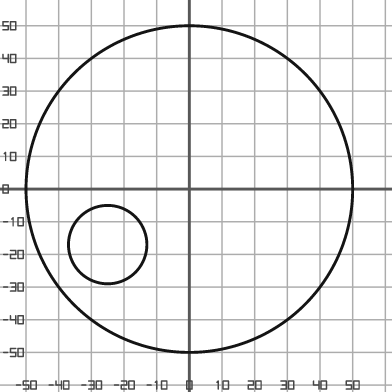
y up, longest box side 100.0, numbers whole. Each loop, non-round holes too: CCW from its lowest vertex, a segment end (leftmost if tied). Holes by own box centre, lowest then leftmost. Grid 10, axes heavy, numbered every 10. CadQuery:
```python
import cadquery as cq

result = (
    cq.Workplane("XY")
    .moveTo(0.0, 0.0)
    .circle(50.0)
    .moveTo(-25.0, -17.0)
    .circle(12.0)
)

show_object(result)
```